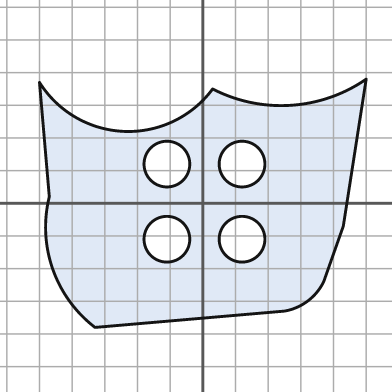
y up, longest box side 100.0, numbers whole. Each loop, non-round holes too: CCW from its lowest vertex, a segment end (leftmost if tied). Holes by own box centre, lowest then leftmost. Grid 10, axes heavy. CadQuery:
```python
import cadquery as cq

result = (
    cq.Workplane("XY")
    .moveTo(-33.0, -38.0)
    .lineTo(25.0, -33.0)
    .threePointArc((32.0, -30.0), (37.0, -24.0))
    .lineTo(43.0, -7.0)
    .lineTo(50.0, 38.0)
    .threePointArc((27.0, 30.0), (3.0, 35.0))
    .threePointArc((-24.0, 22.0), (-50.0, 37.0))
    .lineTo(-47.0, 2.0)
    .threePointArc((-46.0, -20.0), (-33.0, -38.0))
    .close()
    .moveTo(-11.0, -11.0)
    .circle(7.0)
    .moveTo(12.0, -11.0)
    .circle(7.0)
    .moveTo(-11.0, 12.0)
    .circle(7.0)
    .moveTo(12.0, 12.0)
    .circle(7.0)
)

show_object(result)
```